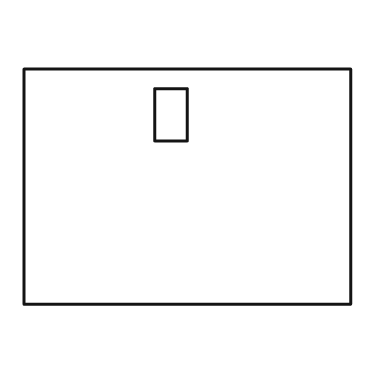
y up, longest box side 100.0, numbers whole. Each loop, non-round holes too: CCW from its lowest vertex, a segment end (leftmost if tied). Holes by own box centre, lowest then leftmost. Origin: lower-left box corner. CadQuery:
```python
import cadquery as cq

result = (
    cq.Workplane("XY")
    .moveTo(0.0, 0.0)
    .lineTo(100.0, 0.0)
    .lineTo(100.0, 72.0)
    .lineTo(0.0, 72.0)
    .close()
    .moveTo(40.0, 50.0)
    .lineTo(50.0, 50.0)
    .lineTo(50.0, 66.0)
    .lineTo(40.0, 66.0)
    .close()
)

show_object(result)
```